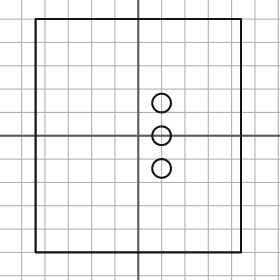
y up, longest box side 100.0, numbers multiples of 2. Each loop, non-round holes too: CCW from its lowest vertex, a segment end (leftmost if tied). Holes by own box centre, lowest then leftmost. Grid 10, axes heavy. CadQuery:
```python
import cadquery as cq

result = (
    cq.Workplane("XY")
    .moveTo(-44.0, -50.0)
    .lineTo(44.0, -50.0)
    .lineTo(44.0, 50.0)
    .lineTo(-44.0, 50.0)
    .close()
    .moveTo(10.0, -14.0)
    .circle(4.0)
    .moveTo(10.0, 0.0)
    .circle(4.0)
    .moveTo(10.0, 14.0)
    .circle(4.0)
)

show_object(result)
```